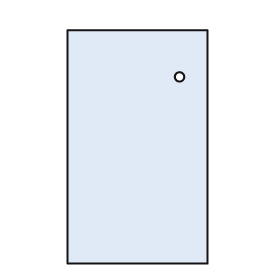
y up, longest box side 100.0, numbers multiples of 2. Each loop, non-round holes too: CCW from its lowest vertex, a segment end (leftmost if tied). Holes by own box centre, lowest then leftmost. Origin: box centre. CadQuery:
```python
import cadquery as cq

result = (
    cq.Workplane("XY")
    .moveTo(-30.0, -50.0)
    .lineTo(30.0, -50.0)
    .lineTo(30.0, 50.0)
    .lineTo(-30.0, 50.0)
    .close()
    .moveTo(18.0, 30.0)
    .circle(2.0)
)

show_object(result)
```